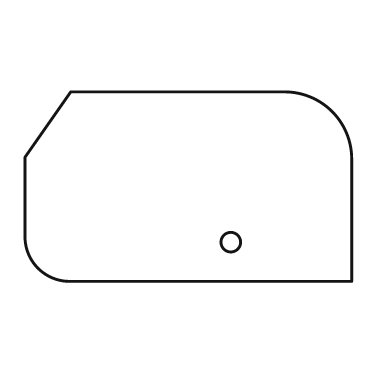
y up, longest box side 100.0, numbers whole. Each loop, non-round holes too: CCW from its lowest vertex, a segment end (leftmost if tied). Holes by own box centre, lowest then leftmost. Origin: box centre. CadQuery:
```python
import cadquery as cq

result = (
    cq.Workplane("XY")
    .moveTo(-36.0, -29.0)
    .lineTo(50.0, -29.0)
    .lineTo(50.0, 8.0)
    .threePointArc((44.0, 23.0), (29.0, 29.0))
    .lineTo(-36.0, 29.0)
    .lineTo(-50.0, 9.0)
    .lineTo(-50.0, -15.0)
    .threePointArc((-46.0, -25.0), (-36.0, -29.0))
    .close()
    .moveTo(13.0, -17.0)
    .circle(3.0)
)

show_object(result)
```